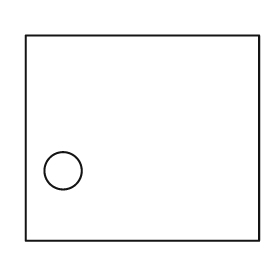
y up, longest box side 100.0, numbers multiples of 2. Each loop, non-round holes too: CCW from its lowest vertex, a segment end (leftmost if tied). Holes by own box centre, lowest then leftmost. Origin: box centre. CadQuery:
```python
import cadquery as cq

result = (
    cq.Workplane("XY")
    .moveTo(-50.0, -44.0)
    .lineTo(50.0, -44.0)
    .lineTo(50.0, 44.0)
    .lineTo(-50.0, 44.0)
    .close()
    .moveTo(-34.0, -14.0)
    .circle(8.0)
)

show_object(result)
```